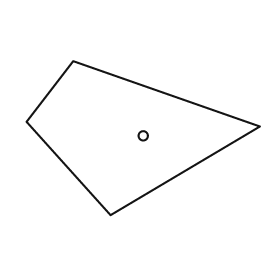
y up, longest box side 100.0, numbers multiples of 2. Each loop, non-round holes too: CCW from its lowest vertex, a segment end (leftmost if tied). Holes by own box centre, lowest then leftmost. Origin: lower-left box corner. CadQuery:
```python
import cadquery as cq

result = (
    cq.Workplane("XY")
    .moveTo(36.0, 0.0)
    .lineTo(100.0, 38.0)
    .lineTo(20.0, 66.0)
    .lineTo(0.0, 40.0)
    .close()
    .moveTo(50.0, 34.0)
    .circle(2.0)
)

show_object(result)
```